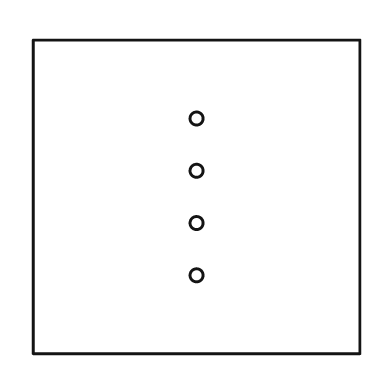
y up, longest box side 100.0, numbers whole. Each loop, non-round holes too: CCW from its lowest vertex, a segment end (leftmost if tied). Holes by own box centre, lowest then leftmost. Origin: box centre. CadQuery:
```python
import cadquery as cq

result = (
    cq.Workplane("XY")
    .moveTo(-50.0, -48.0)
    .lineTo(50.0, -48.0)
    .lineTo(50.0, 48.0)
    .lineTo(-50.0, 48.0)
    .close()
    .moveTo(0.0, -24.0)
    .circle(2.0)
    .moveTo(0.0, -8.0)
    .circle(2.0)
    .moveTo(0.0, 8.0)
    .circle(2.0)
    .moveTo(0.0, 24.0)
    .circle(2.0)
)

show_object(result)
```